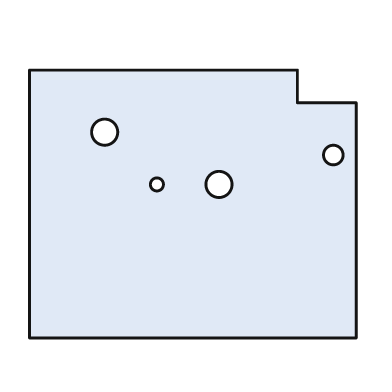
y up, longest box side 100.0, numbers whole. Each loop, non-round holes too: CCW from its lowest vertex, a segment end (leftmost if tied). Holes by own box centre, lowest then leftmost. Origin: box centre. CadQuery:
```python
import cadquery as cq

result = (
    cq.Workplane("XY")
    .moveTo(-50.0, -41.0)
    .lineTo(50.0, -41.0)
    .lineTo(50.0, 31.0)
    .lineTo(32.0, 31.0)
    .lineTo(32.0, 41.0)
    .lineTo(-50.0, 41.0)
    .close()
    .moveTo(-11.0, 6.0)
    .circle(2.0)
    .moveTo(8.0, 6.0)
    .circle(4.0)
    .moveTo(43.0, 15.0)
    .circle(3.0)
    .moveTo(-27.0, 22.0)
    .circle(4.0)
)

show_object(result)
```